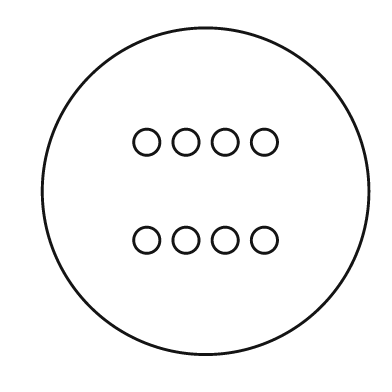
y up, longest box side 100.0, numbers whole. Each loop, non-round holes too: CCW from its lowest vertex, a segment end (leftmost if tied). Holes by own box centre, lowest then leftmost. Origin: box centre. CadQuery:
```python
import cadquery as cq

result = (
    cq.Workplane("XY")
    .moveTo(0.0, 0.0)
    .circle(50.0)
    .moveTo(-18.0, -15.0)
    .circle(4.0)
    .moveTo(-6.0, -15.0)
    .circle(4.0)
    .moveTo(6.0, -15.0)
    .circle(4.0)
    .moveTo(18.0, -15.0)
    .circle(4.0)
    .moveTo(-18.0, 15.0)
    .circle(4.0)
    .moveTo(-6.0, 15.0)
    .circle(4.0)
    .moveTo(6.0, 15.0)
    .circle(4.0)
    .moveTo(18.0, 15.0)
    .circle(4.0)
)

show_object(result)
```